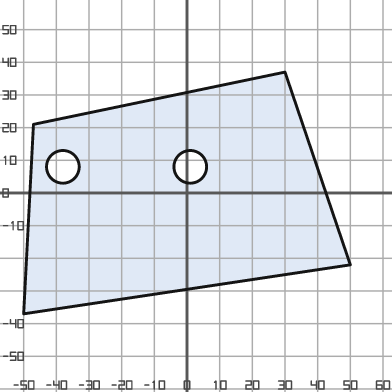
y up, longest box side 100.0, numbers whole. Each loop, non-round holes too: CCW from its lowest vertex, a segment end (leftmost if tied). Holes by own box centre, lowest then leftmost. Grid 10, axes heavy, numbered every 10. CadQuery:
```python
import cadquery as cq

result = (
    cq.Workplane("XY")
    .moveTo(-50.0, -37.0)
    .lineTo(50.0, -22.0)
    .lineTo(30.0, 37.0)
    .lineTo(-47.0, 21.0)
    .close()
    .moveTo(-38.0, 8.0)
    .circle(5.0)
    .moveTo(1.0, 8.0)
    .circle(5.0)
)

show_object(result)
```